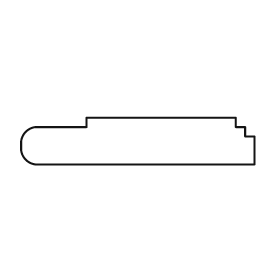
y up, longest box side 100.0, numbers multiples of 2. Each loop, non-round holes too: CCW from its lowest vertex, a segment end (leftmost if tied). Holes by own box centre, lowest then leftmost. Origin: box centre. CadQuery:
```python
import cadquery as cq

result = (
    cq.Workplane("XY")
    .moveTo(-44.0, -10.0)
    .lineTo(50.0, -10.0)
    .lineTo(50.0, 2.0)
    .lineTo(46.0, 2.0)
    .lineTo(46.0, 6.0)
    .lineTo(42.0, 6.0)
    .lineTo(42.0, 10.0)
    .lineTo(-22.0, 10.0)
    .lineTo(-22.0, 6.0)
    .lineTo(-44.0, 6.0)
    .threePointArc((-48.0, 4.0), (-50.0, 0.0))
    .lineTo(-50.0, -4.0)
    .threePointArc((-48.0, -8.0), (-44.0, -10.0))
    .close()
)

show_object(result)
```